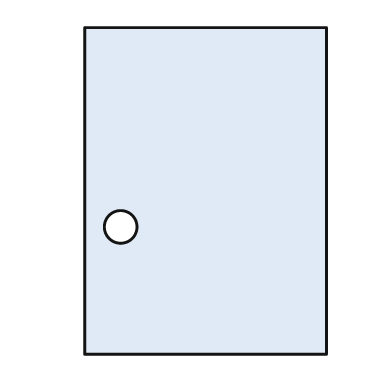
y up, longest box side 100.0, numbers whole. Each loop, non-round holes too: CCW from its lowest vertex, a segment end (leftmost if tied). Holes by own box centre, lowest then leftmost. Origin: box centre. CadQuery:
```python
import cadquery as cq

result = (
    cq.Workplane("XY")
    .moveTo(-37.0, -50.0)
    .lineTo(37.0, -50.0)
    .lineTo(37.0, 50.0)
    .lineTo(-37.0, 50.0)
    .close()
    .moveTo(-26.0, -11.0)
    .circle(5.0)
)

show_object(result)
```